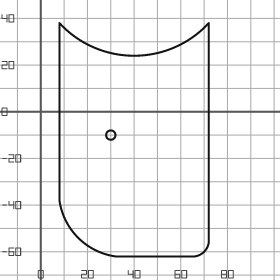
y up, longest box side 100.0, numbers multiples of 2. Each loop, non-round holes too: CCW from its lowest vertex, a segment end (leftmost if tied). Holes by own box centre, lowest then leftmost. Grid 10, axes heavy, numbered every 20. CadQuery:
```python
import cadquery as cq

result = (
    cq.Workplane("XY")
    .moveTo(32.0, -62.0)
    .lineTo(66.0, -62.0)
    .threePointArc((70.0, -60.0), (72.0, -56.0))
    .lineTo(72.0, 38.0)
    .threePointArc((40.0, 24.0), (8.0, 38.0))
    .lineTo(8.0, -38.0)
    .threePointArc((16.0, -54.0), (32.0, -62.0))
    .close()
    .moveTo(30.0, -10.0)
    .circle(2.0)
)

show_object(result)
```